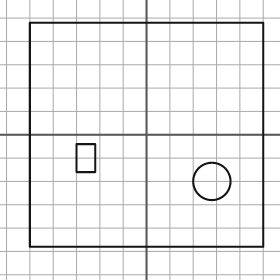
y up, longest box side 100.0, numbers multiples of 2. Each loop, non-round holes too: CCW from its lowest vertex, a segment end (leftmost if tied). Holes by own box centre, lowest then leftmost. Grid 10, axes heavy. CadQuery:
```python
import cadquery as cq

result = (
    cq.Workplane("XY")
    .moveTo(-50.0, -48.0)
    .lineTo(50.0, -48.0)
    .lineTo(50.0, 48.0)
    .lineTo(-50.0, 48.0)
    .close()
    .moveTo(28.0, -20.0)
    .circle(8.0)
    .moveTo(-30.0, -16.0)
    .lineTo(-22.0, -16.0)
    .lineTo(-22.0, -4.0)
    .lineTo(-30.0, -4.0)
    .close()
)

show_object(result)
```